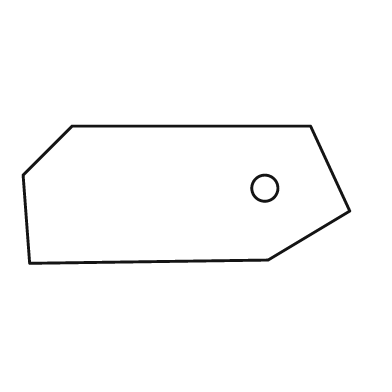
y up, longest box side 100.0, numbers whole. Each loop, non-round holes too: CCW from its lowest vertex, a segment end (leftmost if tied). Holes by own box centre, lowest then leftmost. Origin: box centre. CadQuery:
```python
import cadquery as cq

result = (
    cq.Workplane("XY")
    .moveTo(-48.0, -21.0)
    .lineTo(25.0, -20.0)
    .lineTo(50.0, -5.0)
    .lineTo(38.0, 21.0)
    .lineTo(-35.0, 21.0)
    .lineTo(-50.0, 6.0)
    .close()
    .moveTo(24.0, 2.0)
    .circle(4.0)
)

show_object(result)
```